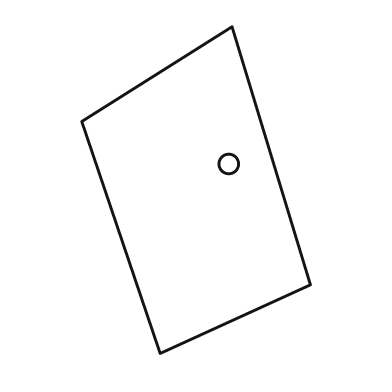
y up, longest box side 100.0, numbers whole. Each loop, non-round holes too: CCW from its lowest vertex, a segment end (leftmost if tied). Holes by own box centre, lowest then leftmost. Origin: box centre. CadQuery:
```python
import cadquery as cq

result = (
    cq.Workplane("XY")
    .moveTo(-11.0, -50.0)
    .lineTo(35.0, -29.0)
    .lineTo(11.0, 50.0)
    .lineTo(-35.0, 21.0)
    .close()
    .moveTo(10.0, 8.0)
    .circle(3.0)
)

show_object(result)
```